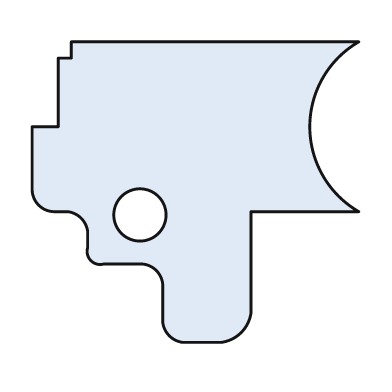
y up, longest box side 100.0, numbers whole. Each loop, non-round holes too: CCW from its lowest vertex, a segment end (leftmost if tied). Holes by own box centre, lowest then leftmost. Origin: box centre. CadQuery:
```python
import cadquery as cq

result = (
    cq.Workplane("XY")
    .moveTo(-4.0, -46.0)
    .lineTo(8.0, -46.0)
    .threePointArc((14.0, -43.0), (17.0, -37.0))
    .lineTo(17.0, -6.0)
    .lineTo(50.0, -6.0)
    .threePointArc((35.0, 20.0), (50.0, 46.0))
    .lineTo(-38.0, 46.0)
    .lineTo(-38.0, 41.0)
    .lineTo(-42.0, 41.0)
    .lineTo(-42.0, 20.0)
    .lineTo(-50.0, 20.0)
    .lineTo(-50.0, 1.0)
    .threePointArc((-48.0, -4.0), (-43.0, -6.0))
    .lineTo(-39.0, -6.0)
    .threePointArc((-35.0, -8.0), (-33.0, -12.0))
    .lineTo(-33.0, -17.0)
    .threePointArc((-32.0, -21.0), (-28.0, -22.0))
    .lineTo(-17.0, -22.0)
    .threePointArc((-12.0, -24.0), (-10.0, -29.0))
    .lineTo(-10.0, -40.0)
    .threePointArc((-8.0, -44.0), (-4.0, -46.0))
    .close()
    .moveTo(-17.0, -7.0)
    .circle(8.0)
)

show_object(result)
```